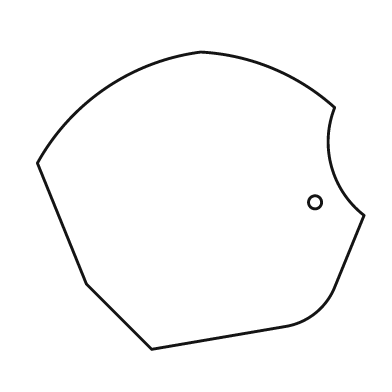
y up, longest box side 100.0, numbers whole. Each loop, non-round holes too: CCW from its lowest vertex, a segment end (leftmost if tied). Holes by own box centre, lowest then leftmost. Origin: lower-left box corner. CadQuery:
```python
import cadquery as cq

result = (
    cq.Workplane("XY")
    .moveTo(35.0, 0.0)
    .lineTo(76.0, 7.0)
    .threePointArc((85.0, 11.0), (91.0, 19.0))
    .lineTo(100.0, 41.0)
    .threePointArc((90.0, 56.0), (91.0, 74.0))
    .threePointArc((72.0, 86.0), (50.0, 91.0))
    .threePointArc((21.0, 80.0), (0.0, 57.0))
    .lineTo(15.0, 20.0)
    .close()
    .moveTo(85.0, 45.0)
    .circle(2.0)
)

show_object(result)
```